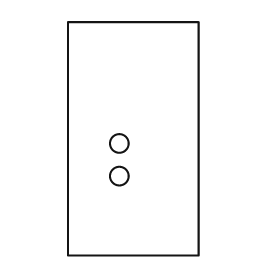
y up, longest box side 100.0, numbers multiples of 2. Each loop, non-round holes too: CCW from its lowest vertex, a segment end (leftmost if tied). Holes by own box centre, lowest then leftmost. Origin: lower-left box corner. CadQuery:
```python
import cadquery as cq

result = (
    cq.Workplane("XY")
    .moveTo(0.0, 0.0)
    .lineTo(56.0, 0.0)
    .lineTo(56.0, 100.0)
    .lineTo(0.0, 100.0)
    .close()
    .moveTo(22.0, 34.0)
    .circle(4.0)
    .moveTo(22.0, 48.0)
    .circle(4.0)
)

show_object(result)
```